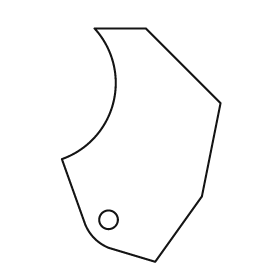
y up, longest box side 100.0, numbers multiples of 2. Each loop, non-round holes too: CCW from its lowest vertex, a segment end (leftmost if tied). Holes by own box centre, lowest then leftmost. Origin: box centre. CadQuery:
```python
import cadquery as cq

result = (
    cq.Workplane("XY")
    .moveTo(6.0, -50.0)
    .lineTo(26.0, -22.0)
    .lineTo(34.0, 18.0)
    .lineTo(2.0, 50.0)
    .lineTo(-20.0, 50.0)
    .threePointArc((-12.0, 18.0), (-34.0, -6.0))
    .lineTo(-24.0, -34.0)
    .threePointArc((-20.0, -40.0), (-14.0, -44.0))
    .close()
    .moveTo(-14.0, -32.0)
    .circle(4.0)
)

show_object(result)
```